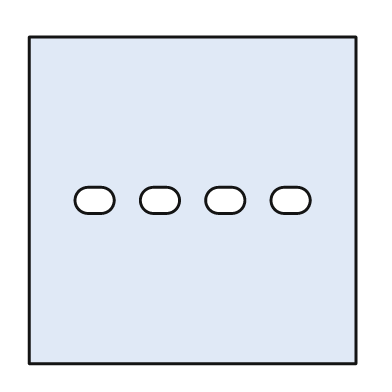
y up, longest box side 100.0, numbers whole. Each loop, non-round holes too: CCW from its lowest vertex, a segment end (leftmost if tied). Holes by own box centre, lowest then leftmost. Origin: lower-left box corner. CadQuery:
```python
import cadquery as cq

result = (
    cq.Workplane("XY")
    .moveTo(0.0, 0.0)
    .lineTo(100.0, 0.0)
    .lineTo(100.0, 100.0)
    .lineTo(0.0, 100.0)
    .close()
    .moveTo(18.0, 46.0)
    .lineTo(22.0, 46.0)
    .threePointArc((26.0, 50.0), (22.0, 54.0))
    .lineTo(18.0, 54.0)
    .threePointArc((14.0, 50.0), (18.0, 46.0))
    .close()
    .moveTo(38.0, 46.0)
    .lineTo(42.0, 46.0)
    .threePointArc((46.0, 50.0), (42.0, 54.0))
    .lineTo(38.0, 54.0)
    .threePointArc((34.0, 50.0), (38.0, 46.0))
    .close()
    .moveTo(58.0, 46.0)
    .lineTo(62.0, 46.0)
    .threePointArc((66.0, 50.0), (62.0, 54.0))
    .lineTo(58.0, 54.0)
    .threePointArc((54.0, 50.0), (58.0, 46.0))
    .close()
    .moveTo(78.0, 46.0)
    .lineTo(82.0, 46.0)
    .threePointArc((86.0, 50.0), (82.0, 54.0))
    .lineTo(78.0, 54.0)
    .threePointArc((74.0, 50.0), (78.0, 46.0))
    .close()
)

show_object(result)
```